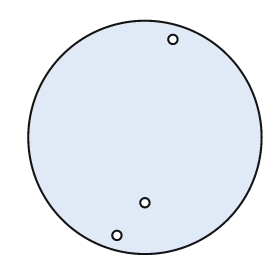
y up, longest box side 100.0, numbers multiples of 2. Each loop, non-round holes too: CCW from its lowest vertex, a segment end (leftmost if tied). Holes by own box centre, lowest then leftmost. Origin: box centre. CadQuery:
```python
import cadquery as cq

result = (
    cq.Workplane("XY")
    .moveTo(0.0, 0.0)
    .circle(50.0)
    .moveTo(-12.0, -42.0)
    .circle(2.0)
    .moveTo(0.0, -28.0)
    .circle(2.0)
    .moveTo(12.0, 42.0)
    .circle(2.0)
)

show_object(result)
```